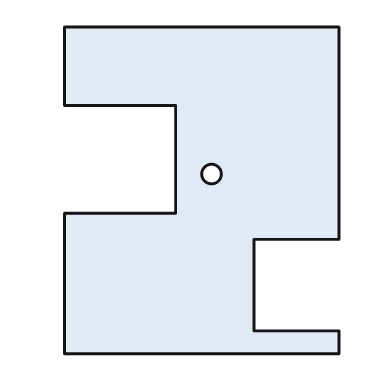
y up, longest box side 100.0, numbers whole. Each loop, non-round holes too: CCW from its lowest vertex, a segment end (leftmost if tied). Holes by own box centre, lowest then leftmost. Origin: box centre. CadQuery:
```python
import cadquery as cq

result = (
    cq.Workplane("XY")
    .moveTo(-42.0, -50.0)
    .lineTo(42.0, -50.0)
    .lineTo(42.0, -43.0)
    .lineTo(16.0, -43.0)
    .lineTo(16.0, -15.0)
    .lineTo(42.0, -15.0)
    .lineTo(42.0, 50.0)
    .lineTo(-42.0, 50.0)
    .lineTo(-42.0, 26.0)
    .lineTo(-8.0, 26.0)
    .lineTo(-8.0, -7.0)
    .lineTo(-42.0, -7.0)
    .close()
    .moveTo(3.0, 5.0)
    .circle(3.0)
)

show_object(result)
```